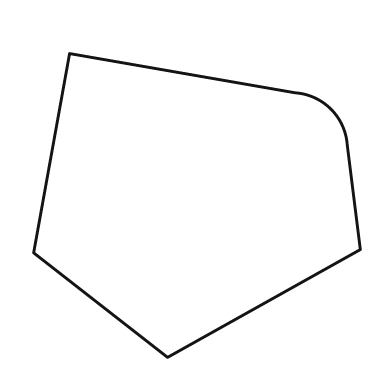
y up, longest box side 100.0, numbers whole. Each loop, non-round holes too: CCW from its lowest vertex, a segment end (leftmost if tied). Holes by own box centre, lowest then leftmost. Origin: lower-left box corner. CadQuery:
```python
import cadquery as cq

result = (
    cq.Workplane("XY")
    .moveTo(41.0, 0.0)
    .lineTo(100.0, 33.0)
    .lineTo(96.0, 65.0)
    .threePointArc((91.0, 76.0), (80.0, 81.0))
    .lineTo(11.0, 93.0)
    .lineTo(0.0, 32.0)
    .close()
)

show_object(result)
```